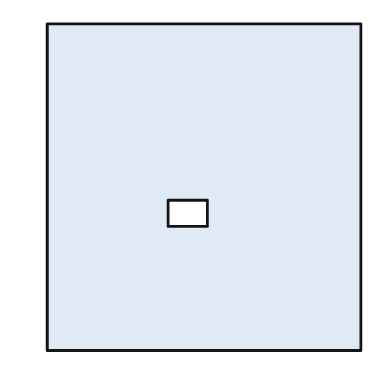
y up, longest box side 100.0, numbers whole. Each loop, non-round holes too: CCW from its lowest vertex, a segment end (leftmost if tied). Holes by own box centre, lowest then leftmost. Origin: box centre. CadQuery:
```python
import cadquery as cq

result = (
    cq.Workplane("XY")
    .moveTo(-48.0, -50.0)
    .lineTo(48.0, -50.0)
    .lineTo(48.0, 50.0)
    .lineTo(-48.0, 50.0)
    .close()
    .moveTo(-11.0, -12.0)
    .lineTo(1.0, -12.0)
    .lineTo(1.0, -4.0)
    .lineTo(-11.0, -4.0)
    .close()
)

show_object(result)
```